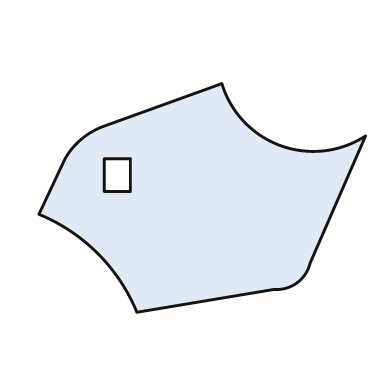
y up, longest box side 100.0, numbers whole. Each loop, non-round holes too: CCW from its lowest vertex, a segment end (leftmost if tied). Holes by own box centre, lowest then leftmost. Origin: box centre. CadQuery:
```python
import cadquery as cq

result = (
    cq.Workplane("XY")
    .moveTo(-20.0, -35.0)
    .lineTo(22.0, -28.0)
    .threePointArc((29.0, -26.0), (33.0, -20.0))
    .lineTo(50.0, 19.0)
    .threePointArc((24.0, 16.0), (6.0, 35.0))
    .lineTo(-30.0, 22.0)
    .threePointArc((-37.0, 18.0), (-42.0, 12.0))
    .lineTo(-50.0, -5.0)
    .threePointArc((-32.0, -17.0), (-20.0, -35.0))
    .close()
    .moveTo(-30.0, 2.0)
    .lineTo(-22.0, 2.0)
    .lineTo(-22.0, 12.0)
    .lineTo(-30.0, 12.0)
    .close()
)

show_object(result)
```